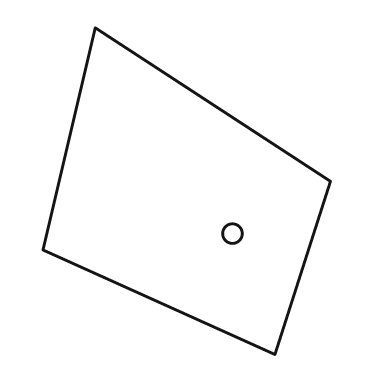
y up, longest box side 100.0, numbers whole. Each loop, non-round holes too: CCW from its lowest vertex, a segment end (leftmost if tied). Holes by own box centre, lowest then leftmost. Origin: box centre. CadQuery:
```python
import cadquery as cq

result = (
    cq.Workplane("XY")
    .moveTo(27.0, -50.0)
    .lineTo(44.0, 3.0)
    .lineTo(-28.0, 50.0)
    .lineTo(-44.0, -18.0)
    .close()
    .moveTo(14.0, -13.0)
    .circle(3.0)
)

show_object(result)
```